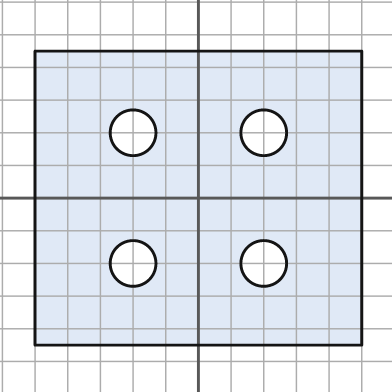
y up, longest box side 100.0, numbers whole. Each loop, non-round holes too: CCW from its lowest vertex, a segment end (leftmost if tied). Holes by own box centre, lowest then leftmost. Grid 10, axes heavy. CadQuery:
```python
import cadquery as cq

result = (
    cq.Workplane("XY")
    .moveTo(-50.0, -45.0)
    .lineTo(50.0, -45.0)
    .lineTo(50.0, 45.0)
    .lineTo(-50.0, 45.0)
    .close()
    .moveTo(-20.0, -20.0)
    .circle(7.0)
    .moveTo(20.0, -20.0)
    .circle(7.0)
    .moveTo(-20.0, 20.0)
    .circle(7.0)
    .moveTo(20.0, 20.0)
    .circle(7.0)
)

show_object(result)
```